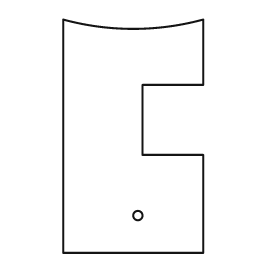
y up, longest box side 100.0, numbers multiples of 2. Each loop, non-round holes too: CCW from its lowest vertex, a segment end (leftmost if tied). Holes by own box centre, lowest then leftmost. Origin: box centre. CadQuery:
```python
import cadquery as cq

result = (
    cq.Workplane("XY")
    .moveTo(-30.0, -50.0)
    .lineTo(30.0, -50.0)
    .lineTo(30.0, -8.0)
    .lineTo(4.0, -8.0)
    .lineTo(4.0, 22.0)
    .lineTo(30.0, 22.0)
    .lineTo(30.0, 50.0)
    .threePointArc((0.0, 46.0), (-30.0, 50.0))
    .close()
    .moveTo(2.0, -34.0)
    .circle(2.0)
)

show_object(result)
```